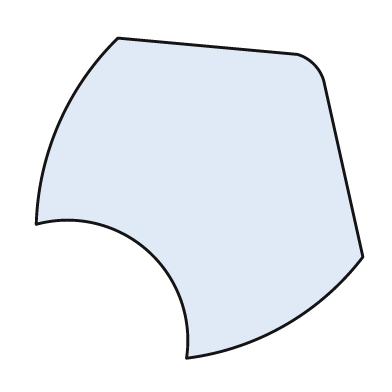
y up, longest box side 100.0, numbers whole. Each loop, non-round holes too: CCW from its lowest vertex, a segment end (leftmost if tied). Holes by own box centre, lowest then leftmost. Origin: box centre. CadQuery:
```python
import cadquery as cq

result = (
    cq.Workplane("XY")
    .moveTo(-4.0, -49.0)
    .threePointArc((26.0, -39.0), (50.0, -18.0))
    .lineTo(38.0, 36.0)
    .threePointArc((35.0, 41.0), (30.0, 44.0))
    .lineTo(-25.0, 49.0)
    .threePointArc((-43.0, 23.0), (-50.0, -8.0))
    .threePointArc((-16.0, -16.0), (-4.0, -49.0))
    .close()
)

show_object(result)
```